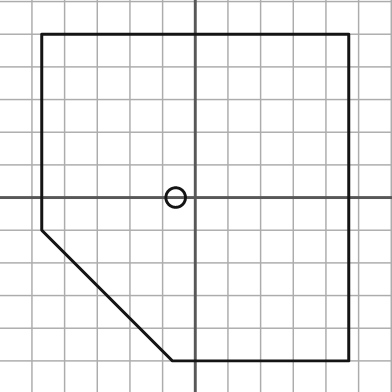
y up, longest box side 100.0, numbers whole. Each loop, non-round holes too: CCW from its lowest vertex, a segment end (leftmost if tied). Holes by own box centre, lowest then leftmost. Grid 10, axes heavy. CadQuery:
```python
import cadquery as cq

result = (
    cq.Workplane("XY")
    .moveTo(-7.0, -50.0)
    .lineTo(47.0, -50.0)
    .lineTo(47.0, 50.0)
    .lineTo(-47.0, 50.0)
    .lineTo(-47.0, -10.0)
    .close()
    .moveTo(-6.0, 0.0)
    .circle(3.0)
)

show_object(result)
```